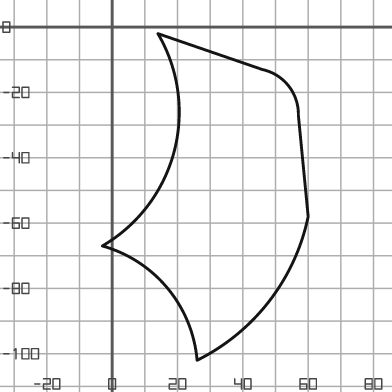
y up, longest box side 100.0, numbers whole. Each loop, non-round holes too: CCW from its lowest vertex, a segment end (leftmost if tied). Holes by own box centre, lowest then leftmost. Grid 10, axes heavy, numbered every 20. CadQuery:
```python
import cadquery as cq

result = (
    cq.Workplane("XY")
    .moveTo(26.0, -102.0)
    .threePointArc((48.0, -84.0), (60.0, -58.0))
    .lineTo(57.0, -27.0)
    .threePointArc((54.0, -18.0), (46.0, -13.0))
    .lineTo(14.0, -2.0)
    .threePointArc((19.0, -38.0), (-3.0, -67.0))
    .threePointArc((17.0, -80.0), (26.0, -102.0))
    .close()
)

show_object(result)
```